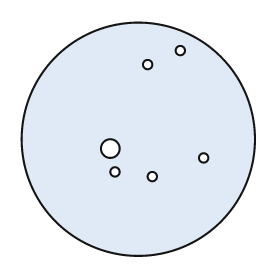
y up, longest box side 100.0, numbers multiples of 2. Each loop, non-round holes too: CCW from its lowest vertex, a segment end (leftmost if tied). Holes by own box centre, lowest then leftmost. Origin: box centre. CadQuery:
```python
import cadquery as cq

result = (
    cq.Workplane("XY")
    .moveTo(0.0, 0.0)
    .circle(50.0)
    .moveTo(6.0, -16.0)
    .circle(2.0)
    .moveTo(-10.0, -14.0)
    .circle(2.0)
    .moveTo(28.0, -8.0)
    .circle(2.0)
    .moveTo(-12.0, -4.0)
    .circle(4.0)
    .moveTo(4.0, 32.0)
    .circle(2.0)
    .moveTo(18.0, 38.0)
    .circle(2.0)
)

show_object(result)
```